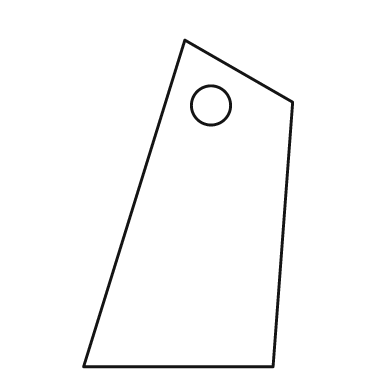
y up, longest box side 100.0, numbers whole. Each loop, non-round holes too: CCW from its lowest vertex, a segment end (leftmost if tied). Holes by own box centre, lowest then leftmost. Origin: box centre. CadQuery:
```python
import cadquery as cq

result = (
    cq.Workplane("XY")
    .moveTo(-32.0, -50.0)
    .lineTo(26.0, -50.0)
    .lineTo(32.0, 31.0)
    .lineTo(-1.0, 50.0)
    .close()
    .moveTo(7.0, 30.0)
    .circle(6.0)
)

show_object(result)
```